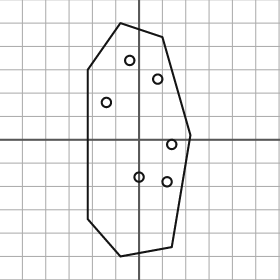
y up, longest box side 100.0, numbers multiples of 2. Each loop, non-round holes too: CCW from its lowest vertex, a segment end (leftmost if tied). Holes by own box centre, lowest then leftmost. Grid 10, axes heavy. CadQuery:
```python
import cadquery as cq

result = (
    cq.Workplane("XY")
    .moveTo(-8.0, -50.0)
    .lineTo(14.0, -46.0)
    .lineTo(22.0, 2.0)
    .lineTo(10.0, 44.0)
    .lineTo(-8.0, 50.0)
    .lineTo(-22.0, 30.0)
    .lineTo(-22.0, -34.0)
    .close()
    .moveTo(12.0, -18.0)
    .circle(2.0)
    .moveTo(0.0, -16.0)
    .circle(2.0)
    .moveTo(14.0, -2.0)
    .circle(2.0)
    .moveTo(-14.0, 16.0)
    .circle(2.0)
    .moveTo(8.0, 26.0)
    .circle(2.0)
    .moveTo(-4.0, 34.0)
    .circle(2.0)
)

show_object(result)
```